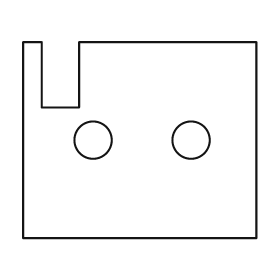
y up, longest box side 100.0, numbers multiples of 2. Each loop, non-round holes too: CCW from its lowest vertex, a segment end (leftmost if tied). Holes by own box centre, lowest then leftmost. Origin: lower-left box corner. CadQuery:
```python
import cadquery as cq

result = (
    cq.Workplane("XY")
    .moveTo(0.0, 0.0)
    .lineTo(100.0, 0.0)
    .lineTo(100.0, 84.0)
    .lineTo(24.0, 84.0)
    .lineTo(24.0, 56.0)
    .lineTo(8.0, 56.0)
    .lineTo(8.0, 84.0)
    .lineTo(0.0, 84.0)
    .close()
    .moveTo(30.0, 42.0)
    .circle(8.0)
    .moveTo(72.0, 42.0)
    .circle(8.0)
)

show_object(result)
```